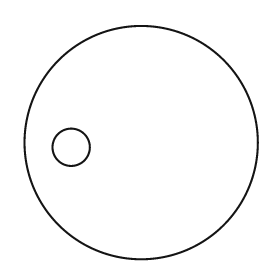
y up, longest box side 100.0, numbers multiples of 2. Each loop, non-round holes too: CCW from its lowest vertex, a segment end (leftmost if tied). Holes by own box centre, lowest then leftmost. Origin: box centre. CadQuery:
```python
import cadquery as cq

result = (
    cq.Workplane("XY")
    .moveTo(0.0, 0.0)
    .circle(50.0)
    .moveTo(-30.0, -2.0)
    .circle(8.0)
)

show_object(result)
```